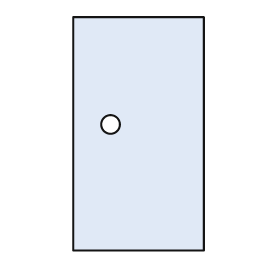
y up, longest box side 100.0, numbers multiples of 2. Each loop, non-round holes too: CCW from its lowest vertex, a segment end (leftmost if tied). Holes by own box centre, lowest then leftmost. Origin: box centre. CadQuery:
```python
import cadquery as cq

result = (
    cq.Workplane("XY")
    .moveTo(-28.0, -50.0)
    .lineTo(28.0, -50.0)
    .lineTo(28.0, 50.0)
    .lineTo(-28.0, 50.0)
    .close()
    .moveTo(-12.0, 4.0)
    .circle(4.0)
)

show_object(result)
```